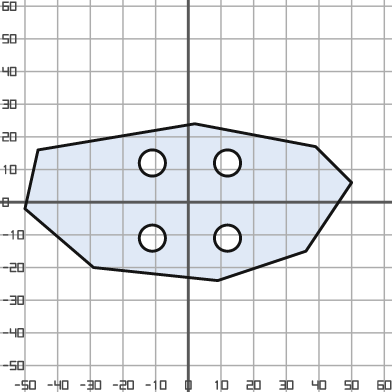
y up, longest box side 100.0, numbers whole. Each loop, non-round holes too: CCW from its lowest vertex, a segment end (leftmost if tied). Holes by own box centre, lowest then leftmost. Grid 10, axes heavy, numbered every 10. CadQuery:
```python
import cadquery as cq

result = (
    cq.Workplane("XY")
    .moveTo(9.0, -24.0)
    .lineTo(36.0, -15.0)
    .lineTo(50.0, 6.0)
    .lineTo(39.0, 17.0)
    .lineTo(2.0, 24.0)
    .lineTo(-46.0, 16.0)
    .lineTo(-50.0, -2.0)
    .lineTo(-29.0, -20.0)
    .close()
    .moveTo(-11.0, -11.0)
    .circle(4.0)
    .moveTo(12.0, -11.0)
    .circle(4.0)
    .moveTo(-11.0, 12.0)
    .circle(4.0)
    .moveTo(12.0, 12.0)
    .circle(4.0)
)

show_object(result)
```